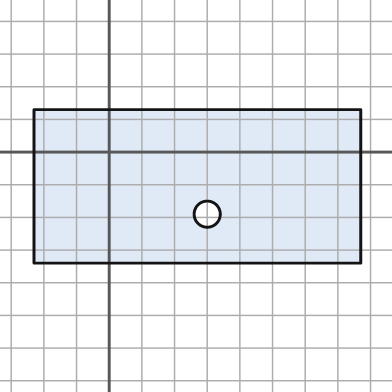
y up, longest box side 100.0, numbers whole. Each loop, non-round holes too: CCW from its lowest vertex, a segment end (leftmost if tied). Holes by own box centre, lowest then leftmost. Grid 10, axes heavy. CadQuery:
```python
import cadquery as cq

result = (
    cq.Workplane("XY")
    .moveTo(-23.0, -34.0)
    .lineTo(77.0, -34.0)
    .lineTo(77.0, 13.0)
    .lineTo(-23.0, 13.0)
    .close()
    .moveTo(30.0, -19.0)
    .circle(4.0)
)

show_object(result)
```